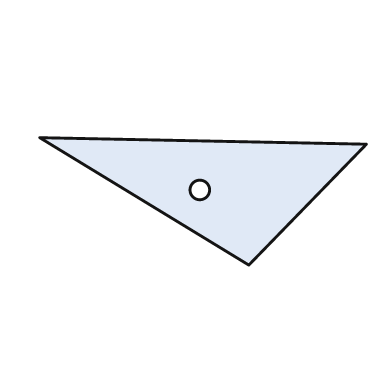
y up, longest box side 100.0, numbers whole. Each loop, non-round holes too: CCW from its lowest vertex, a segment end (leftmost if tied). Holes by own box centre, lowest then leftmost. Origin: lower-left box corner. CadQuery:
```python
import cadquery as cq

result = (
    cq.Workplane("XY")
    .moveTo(64.0, 0.0)
    .lineTo(100.0, 37.0)
    .lineTo(0.0, 39.0)
    .close()
    .moveTo(49.0, 23.0)
    .circle(3.0)
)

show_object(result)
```